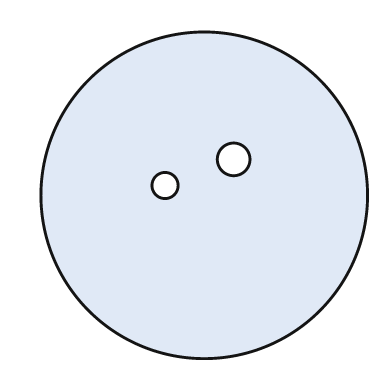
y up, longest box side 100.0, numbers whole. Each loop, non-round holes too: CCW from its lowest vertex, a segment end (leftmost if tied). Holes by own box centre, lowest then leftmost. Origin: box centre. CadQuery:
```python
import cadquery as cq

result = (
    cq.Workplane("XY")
    .moveTo(0.0, 0.0)
    .circle(50.0)
    .moveTo(-12.0, 3.0)
    .circle(4.0)
    .moveTo(9.0, 11.0)
    .circle(5.0)
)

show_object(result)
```